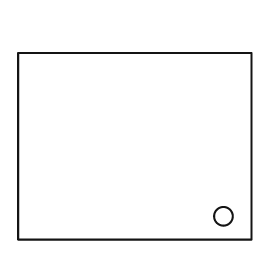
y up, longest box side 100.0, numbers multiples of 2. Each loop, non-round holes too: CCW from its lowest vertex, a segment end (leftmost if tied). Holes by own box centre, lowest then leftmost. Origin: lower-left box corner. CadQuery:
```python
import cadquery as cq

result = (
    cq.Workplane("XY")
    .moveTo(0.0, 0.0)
    .lineTo(100.0, 0.0)
    .lineTo(100.0, 80.0)
    .lineTo(0.0, 80.0)
    .close()
    .moveTo(88.0, 10.0)
    .circle(4.0)
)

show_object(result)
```